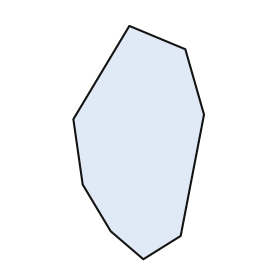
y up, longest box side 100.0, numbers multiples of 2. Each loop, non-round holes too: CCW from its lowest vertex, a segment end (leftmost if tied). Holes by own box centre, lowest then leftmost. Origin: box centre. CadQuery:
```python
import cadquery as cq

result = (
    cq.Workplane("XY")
    .moveTo(2.0, -50.0)
    .lineTo(18.0, -40.0)
    .lineTo(28.0, 12.0)
    .lineTo(20.0, 40.0)
    .lineTo(-4.0, 50.0)
    .lineTo(-28.0, 10.0)
    .lineTo(-24.0, -18.0)
    .lineTo(-12.0, -38.0)
    .close()
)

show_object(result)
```